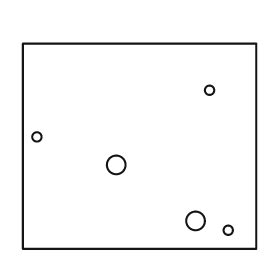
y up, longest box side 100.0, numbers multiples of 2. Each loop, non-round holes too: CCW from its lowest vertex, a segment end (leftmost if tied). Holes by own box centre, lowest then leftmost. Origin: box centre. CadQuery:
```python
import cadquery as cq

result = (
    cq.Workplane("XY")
    .moveTo(-50.0, -44.0)
    .lineTo(50.0, -44.0)
    .lineTo(50.0, 44.0)
    .lineTo(-50.0, 44.0)
    .close()
    .moveTo(38.0, -36.0)
    .circle(2.0)
    .moveTo(24.0, -32.0)
    .circle(4.0)
    .moveTo(-10.0, -8.0)
    .circle(4.0)
    .moveTo(-44.0, 4.0)
    .circle(2.0)
    .moveTo(30.0, 24.0)
    .circle(2.0)
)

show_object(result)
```